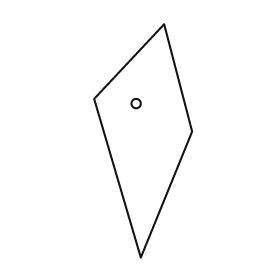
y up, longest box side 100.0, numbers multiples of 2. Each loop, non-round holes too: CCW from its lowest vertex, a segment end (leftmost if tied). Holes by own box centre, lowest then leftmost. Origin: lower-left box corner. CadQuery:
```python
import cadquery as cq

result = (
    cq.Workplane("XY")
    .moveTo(20.0, 0.0)
    .lineTo(42.0, 54.0)
    .lineTo(30.0, 100.0)
    .lineTo(0.0, 68.0)
    .close()
    .moveTo(18.0, 66.0)
    .circle(2.0)
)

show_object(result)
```